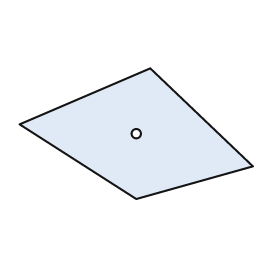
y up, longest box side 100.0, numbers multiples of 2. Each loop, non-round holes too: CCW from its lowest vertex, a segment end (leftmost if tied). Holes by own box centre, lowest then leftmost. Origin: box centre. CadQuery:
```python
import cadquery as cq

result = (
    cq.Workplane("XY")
    .moveTo(0.0, -28.0)
    .lineTo(50.0, -14.0)
    .lineTo(6.0, 28.0)
    .lineTo(-50.0, 4.0)
    .close()
    .moveTo(0.0, 0.0)
    .circle(2.0)
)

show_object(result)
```